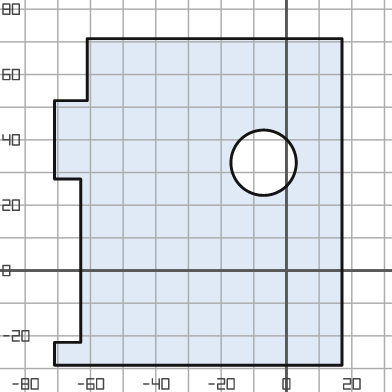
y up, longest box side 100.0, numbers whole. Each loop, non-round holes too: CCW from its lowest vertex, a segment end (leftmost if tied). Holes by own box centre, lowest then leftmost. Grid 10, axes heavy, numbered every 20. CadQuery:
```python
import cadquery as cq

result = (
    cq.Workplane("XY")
    .moveTo(-71.0, -29.0)
    .lineTo(17.0, -29.0)
    .lineTo(17.0, 71.0)
    .lineTo(-61.0, 71.0)
    .lineTo(-61.0, 52.0)
    .lineTo(-71.0, 52.0)
    .lineTo(-71.0, 28.0)
    .lineTo(-63.0, 28.0)
    .lineTo(-63.0, -22.0)
    .lineTo(-71.0, -22.0)
    .close()
    .moveTo(-7.0, 33.0)
    .circle(10.0)
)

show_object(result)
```